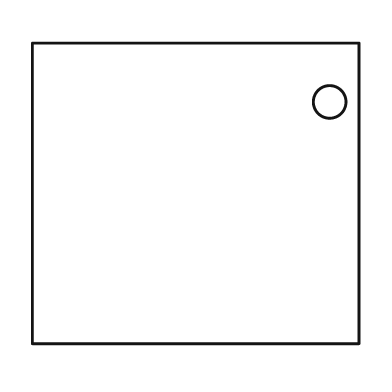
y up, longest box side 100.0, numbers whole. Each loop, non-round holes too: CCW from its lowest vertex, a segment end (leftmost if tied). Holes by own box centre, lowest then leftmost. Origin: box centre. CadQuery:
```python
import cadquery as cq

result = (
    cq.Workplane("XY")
    .moveTo(-50.0, -46.0)
    .lineTo(50.0, -46.0)
    .lineTo(50.0, 46.0)
    .lineTo(-50.0, 46.0)
    .close()
    .moveTo(41.0, 28.0)
    .circle(5.0)
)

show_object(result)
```